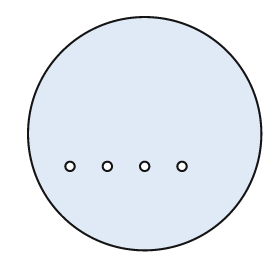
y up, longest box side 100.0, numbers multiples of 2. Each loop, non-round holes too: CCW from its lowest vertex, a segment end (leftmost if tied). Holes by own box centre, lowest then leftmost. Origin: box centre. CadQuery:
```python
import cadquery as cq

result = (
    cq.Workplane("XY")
    .moveTo(0.0, 0.0)
    .circle(50.0)
    .moveTo(-32.0, -14.0)
    .circle(2.0)
    .moveTo(-16.0, -14.0)
    .circle(2.0)
    .moveTo(0.0, -14.0)
    .circle(2.0)
    .moveTo(16.0, -14.0)
    .circle(2.0)
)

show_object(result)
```